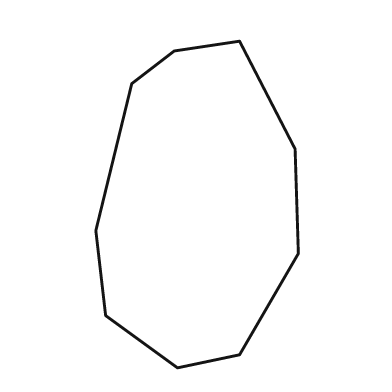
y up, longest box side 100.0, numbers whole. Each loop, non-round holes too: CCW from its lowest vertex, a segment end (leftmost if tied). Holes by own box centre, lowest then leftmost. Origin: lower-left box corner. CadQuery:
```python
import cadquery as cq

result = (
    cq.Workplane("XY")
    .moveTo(25.0, 0.0)
    .lineTo(44.0, 4.0)
    .lineTo(62.0, 35.0)
    .lineTo(61.0, 67.0)
    .lineTo(44.0, 100.0)
    .lineTo(24.0, 97.0)
    .lineTo(11.0, 87.0)
    .lineTo(0.0, 42.0)
    .lineTo(3.0, 16.0)
    .close()
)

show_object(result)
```